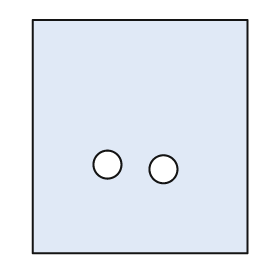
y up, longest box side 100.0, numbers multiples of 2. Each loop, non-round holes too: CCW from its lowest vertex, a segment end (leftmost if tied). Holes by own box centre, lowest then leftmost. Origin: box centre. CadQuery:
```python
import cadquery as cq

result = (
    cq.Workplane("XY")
    .moveTo(-46.0, -50.0)
    .lineTo(46.0, -50.0)
    .lineTo(46.0, 50.0)
    .lineTo(-46.0, 50.0)
    .close()
    .moveTo(10.0, -14.0)
    .circle(6.0)
    .moveTo(-14.0, -12.0)
    .circle(6.0)
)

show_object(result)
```